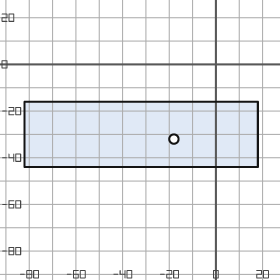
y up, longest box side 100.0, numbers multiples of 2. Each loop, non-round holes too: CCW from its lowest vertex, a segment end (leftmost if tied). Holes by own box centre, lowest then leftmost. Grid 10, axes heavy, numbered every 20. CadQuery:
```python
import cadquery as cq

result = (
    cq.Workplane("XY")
    .moveTo(-82.0, -44.0)
    .lineTo(18.0, -44.0)
    .lineTo(18.0, -16.0)
    .lineTo(-82.0, -16.0)
    .close()
    .moveTo(-18.0, -32.0)
    .circle(2.0)
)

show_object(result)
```